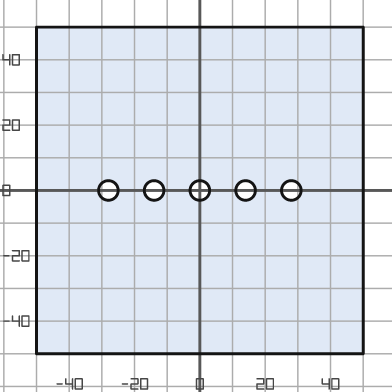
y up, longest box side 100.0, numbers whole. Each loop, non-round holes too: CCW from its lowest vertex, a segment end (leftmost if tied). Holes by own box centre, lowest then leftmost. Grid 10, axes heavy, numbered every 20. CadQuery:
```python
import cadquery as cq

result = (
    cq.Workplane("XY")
    .moveTo(-50.0, -50.0)
    .lineTo(50.0, -50.0)
    .lineTo(50.0, 50.0)
    .lineTo(-50.0, 50.0)
    .close()
    .moveTo(-28.0, 0.0)
    .circle(3.0)
    .moveTo(-14.0, 0.0)
    .circle(3.0)
    .moveTo(0.0, 0.0)
    .circle(3.0)
    .moveTo(14.0, 0.0)
    .circle(3.0)
    .moveTo(28.0, 0.0)
    .circle(3.0)
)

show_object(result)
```